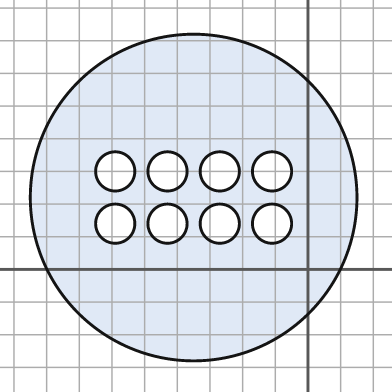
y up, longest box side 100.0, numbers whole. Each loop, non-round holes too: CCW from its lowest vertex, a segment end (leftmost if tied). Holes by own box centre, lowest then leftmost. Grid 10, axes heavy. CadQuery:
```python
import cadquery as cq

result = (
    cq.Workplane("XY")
    .moveTo(-35.0, 22.0)
    .circle(50.0)
    .moveTo(-59.0, 14.0)
    .circle(6.0)
    .moveTo(-43.0, 14.0)
    .circle(6.0)
    .moveTo(-27.0, 14.0)
    .circle(6.0)
    .moveTo(-11.0, 14.0)
    .circle(6.0)
    .moveTo(-59.0, 30.0)
    .circle(6.0)
    .moveTo(-43.0, 30.0)
    .circle(6.0)
    .moveTo(-27.0, 30.0)
    .circle(6.0)
    .moveTo(-11.0, 30.0)
    .circle(6.0)
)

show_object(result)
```